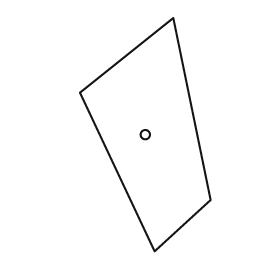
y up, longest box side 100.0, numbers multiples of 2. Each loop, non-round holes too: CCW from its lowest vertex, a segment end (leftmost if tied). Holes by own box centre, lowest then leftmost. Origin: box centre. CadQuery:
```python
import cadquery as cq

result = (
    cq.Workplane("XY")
    .moveTo(4.0, -50.0)
    .lineTo(28.0, -28.0)
    .lineTo(12.0, 50.0)
    .lineTo(-28.0, 18.0)
    .close()
    .moveTo(0.0, 0.0)
    .circle(2.0)
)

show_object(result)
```